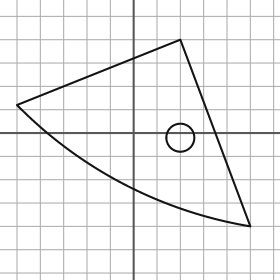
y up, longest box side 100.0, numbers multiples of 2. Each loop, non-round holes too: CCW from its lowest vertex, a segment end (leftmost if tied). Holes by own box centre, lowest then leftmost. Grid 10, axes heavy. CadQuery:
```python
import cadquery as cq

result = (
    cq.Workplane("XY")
    .moveTo(50.0, -40.0)
    .lineTo(20.0, 40.0)
    .lineTo(-50.0, 12.0)
    .threePointArc((-4.0, -22.0), (50.0, -40.0))
    .close()
    .moveTo(20.0, -2.0)
    .circle(6.0)
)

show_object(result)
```